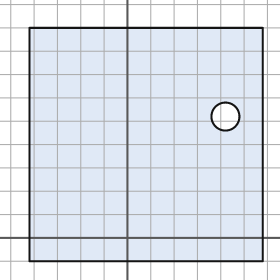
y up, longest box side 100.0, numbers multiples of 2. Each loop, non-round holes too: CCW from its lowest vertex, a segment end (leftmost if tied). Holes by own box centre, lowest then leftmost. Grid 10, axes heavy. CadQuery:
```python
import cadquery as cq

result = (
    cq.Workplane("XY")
    .moveTo(-42.0, -10.0)
    .lineTo(58.0, -10.0)
    .lineTo(58.0, 90.0)
    .lineTo(-42.0, 90.0)
    .close()
    .moveTo(42.0, 52.0)
    .circle(6.0)
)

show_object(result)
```